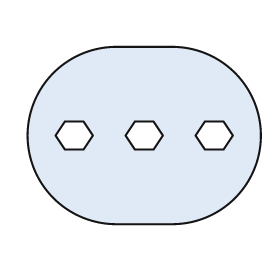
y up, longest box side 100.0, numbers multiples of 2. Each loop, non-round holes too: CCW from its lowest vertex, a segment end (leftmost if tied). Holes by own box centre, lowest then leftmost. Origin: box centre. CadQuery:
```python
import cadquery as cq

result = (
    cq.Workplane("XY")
    .moveTo(-12.0, -38.0)
    .lineTo(12.0, -38.0)
    .threePointArc((50.0, 0.0), (12.0, 38.0))
    .lineTo(-12.0, 38.0)
    .threePointArc((-50.0, 0.0), (-12.0, -38.0))
    .close()
    .moveTo(-34.0, -6.0)
    .lineTo(-26.0, -6.0)
    .lineTo(-22.0, 0.0)
    .lineTo(-26.0, 6.0)
    .lineTo(-34.0, 6.0)
    .lineTo(-38.0, 0.0)
    .close()
    .moveTo(-4.0, -6.0)
    .lineTo(4.0, -6.0)
    .lineTo(8.0, 0.0)
    .lineTo(4.0, 6.0)
    .lineTo(-4.0, 6.0)
    .lineTo(-8.0, 0.0)
    .close()
    .moveTo(26.0, -6.0)
    .lineTo(34.0, -6.0)
    .lineTo(38.0, 0.0)
    .lineTo(34.0, 6.0)
    .lineTo(26.0, 6.0)
    .lineTo(22.0, 0.0)
    .close()
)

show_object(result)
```